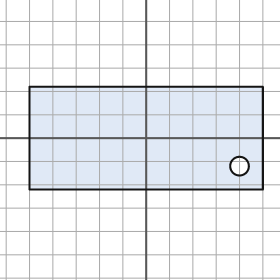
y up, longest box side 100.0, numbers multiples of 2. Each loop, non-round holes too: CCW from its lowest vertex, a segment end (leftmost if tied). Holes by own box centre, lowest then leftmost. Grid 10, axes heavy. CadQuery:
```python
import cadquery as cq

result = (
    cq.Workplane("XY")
    .moveTo(-50.0, -22.0)
    .lineTo(50.0, -22.0)
    .lineTo(50.0, 22.0)
    .lineTo(-50.0, 22.0)
    .close()
    .moveTo(40.0, -12.0)
    .circle(4.0)
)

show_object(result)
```